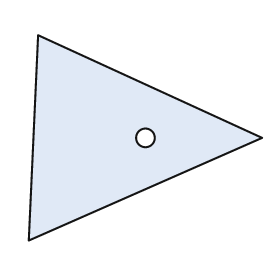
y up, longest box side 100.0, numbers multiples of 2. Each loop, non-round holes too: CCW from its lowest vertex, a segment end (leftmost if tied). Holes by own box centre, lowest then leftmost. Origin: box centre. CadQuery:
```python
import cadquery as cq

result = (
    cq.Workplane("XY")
    .moveTo(-50.0, -44.0)
    .lineTo(50.0, 0.0)
    .lineTo(-46.0, 44.0)
    .close()
    .moveTo(0.0, 0.0)
    .circle(4.0)
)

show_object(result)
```